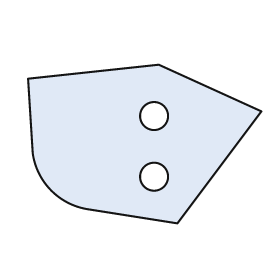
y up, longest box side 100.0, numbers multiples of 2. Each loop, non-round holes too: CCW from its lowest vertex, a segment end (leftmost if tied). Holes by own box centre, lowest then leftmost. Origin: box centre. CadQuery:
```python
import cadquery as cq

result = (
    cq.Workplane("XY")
    .moveTo(14.0, -34.0)
    .lineTo(50.0, 14.0)
    .lineTo(6.0, 34.0)
    .lineTo(-50.0, 28.0)
    .lineTo(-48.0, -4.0)
    .threePointArc((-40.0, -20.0), (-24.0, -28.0))
    .close()
    .moveTo(4.0, -14.0)
    .circle(6.0)
    .moveTo(4.0, 12.0)
    .circle(6.0)
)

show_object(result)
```